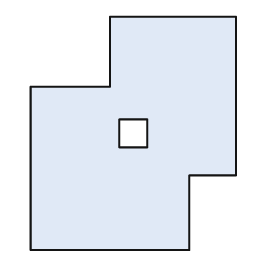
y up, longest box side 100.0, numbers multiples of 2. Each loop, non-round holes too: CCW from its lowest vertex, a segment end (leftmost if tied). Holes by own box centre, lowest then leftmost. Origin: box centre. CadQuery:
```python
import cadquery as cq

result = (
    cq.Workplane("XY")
    .moveTo(-44.0, -50.0)
    .lineTo(24.0, -50.0)
    .lineTo(24.0, -18.0)
    .lineTo(44.0, -18.0)
    .lineTo(44.0, 50.0)
    .lineTo(-10.0, 50.0)
    .lineTo(-10.0, 20.0)
    .lineTo(-44.0, 20.0)
    .close()
    .moveTo(-6.0, -6.0)
    .lineTo(6.0, -6.0)
    .lineTo(6.0, 6.0)
    .lineTo(-6.0, 6.0)
    .close()
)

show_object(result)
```